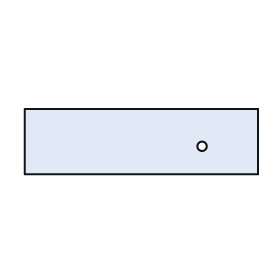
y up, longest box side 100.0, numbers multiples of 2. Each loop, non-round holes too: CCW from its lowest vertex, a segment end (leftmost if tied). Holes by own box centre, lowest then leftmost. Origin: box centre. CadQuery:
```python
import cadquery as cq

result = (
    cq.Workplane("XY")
    .moveTo(-50.0, -14.0)
    .lineTo(50.0, -14.0)
    .lineTo(50.0, 14.0)
    .lineTo(-50.0, 14.0)
    .close()
    .moveTo(26.0, -2.0)
    .circle(2.0)
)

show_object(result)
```